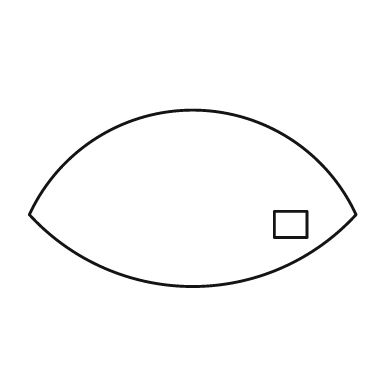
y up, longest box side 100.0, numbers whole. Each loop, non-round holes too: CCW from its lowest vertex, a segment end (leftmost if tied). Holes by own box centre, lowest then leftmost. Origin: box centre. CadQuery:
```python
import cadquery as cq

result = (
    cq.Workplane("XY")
    .moveTo(-50.0, -5.0)
    .threePointArc((0.0, -27.0), (50.0, -5.0))
    .threePointArc((0.0, 27.0), (-50.0, -5.0))
    .close()
    .moveTo(25.0, -12.0)
    .lineTo(35.0, -12.0)
    .lineTo(35.0, -4.0)
    .lineTo(25.0, -4.0)
    .close()
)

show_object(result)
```